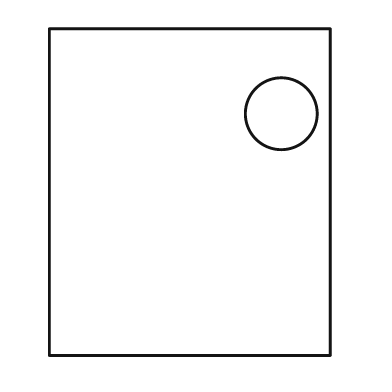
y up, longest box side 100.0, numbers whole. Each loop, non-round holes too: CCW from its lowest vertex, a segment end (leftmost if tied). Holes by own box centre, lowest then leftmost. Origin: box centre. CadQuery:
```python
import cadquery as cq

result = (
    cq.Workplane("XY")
    .moveTo(-43.0, -50.0)
    .lineTo(43.0, -50.0)
    .lineTo(43.0, 50.0)
    .lineTo(-43.0, 50.0)
    .close()
    .moveTo(28.0, 24.0)
    .circle(11.0)
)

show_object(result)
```